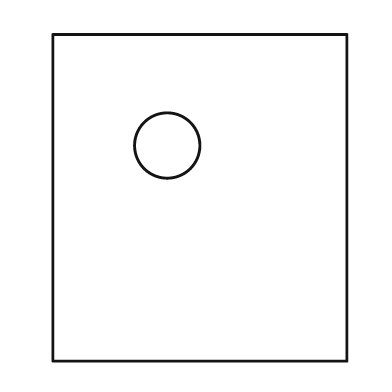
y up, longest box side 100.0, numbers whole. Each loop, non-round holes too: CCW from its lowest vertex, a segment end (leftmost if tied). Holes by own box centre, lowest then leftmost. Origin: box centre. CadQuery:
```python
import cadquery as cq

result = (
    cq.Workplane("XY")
    .moveTo(-45.0, -50.0)
    .lineTo(45.0, -50.0)
    .lineTo(45.0, 50.0)
    .lineTo(-45.0, 50.0)
    .close()
    .moveTo(-10.0, 16.0)
    .circle(10.0)
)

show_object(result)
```